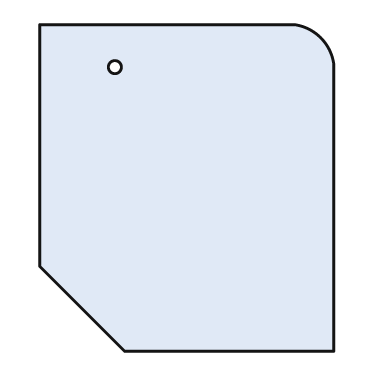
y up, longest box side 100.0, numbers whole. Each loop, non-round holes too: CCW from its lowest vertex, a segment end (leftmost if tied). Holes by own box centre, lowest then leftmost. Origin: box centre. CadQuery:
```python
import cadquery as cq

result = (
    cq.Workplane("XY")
    .moveTo(-19.0, -50.0)
    .lineTo(45.0, -50.0)
    .lineTo(45.0, 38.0)
    .threePointArc((41.0, 46.0), (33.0, 50.0))
    .lineTo(-45.0, 50.0)
    .lineTo(-45.0, -24.0)
    .close()
    .moveTo(-22.0, 37.0)
    .circle(2.0)
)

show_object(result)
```